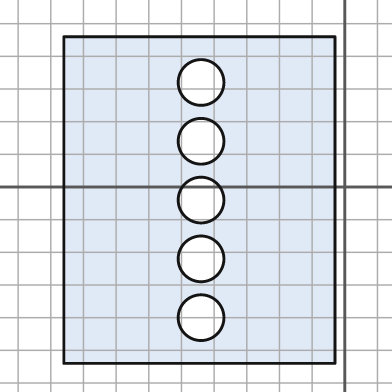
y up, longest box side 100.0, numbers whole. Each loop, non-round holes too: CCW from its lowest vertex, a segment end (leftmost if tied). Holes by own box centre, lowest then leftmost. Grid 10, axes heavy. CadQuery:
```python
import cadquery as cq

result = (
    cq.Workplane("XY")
    .moveTo(-86.0, -54.0)
    .lineTo(-3.0, -54.0)
    .lineTo(-3.0, 46.0)
    .lineTo(-86.0, 46.0)
    .close()
    .moveTo(-44.0, -40.0)
    .circle(7.0)
    .moveTo(-44.0, -22.0)
    .circle(7.0)
    .moveTo(-44.0, -4.0)
    .circle(7.0)
    .moveTo(-44.0, 14.0)
    .circle(7.0)
    .moveTo(-44.0, 32.0)
    .circle(7.0)
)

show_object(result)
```